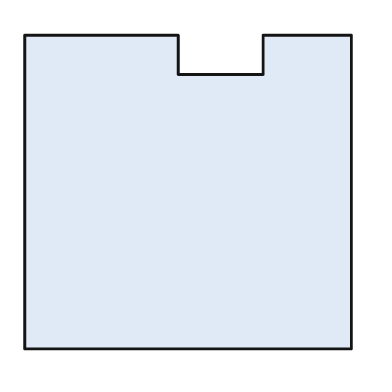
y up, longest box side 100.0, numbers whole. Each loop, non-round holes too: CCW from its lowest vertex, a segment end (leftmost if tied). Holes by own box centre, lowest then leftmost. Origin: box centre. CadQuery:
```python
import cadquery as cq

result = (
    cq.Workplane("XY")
    .moveTo(-50.0, -48.0)
    .lineTo(50.0, -48.0)
    .lineTo(50.0, 48.0)
    .lineTo(23.0, 48.0)
    .lineTo(23.0, 36.0)
    .lineTo(-3.0, 36.0)
    .lineTo(-3.0, 48.0)
    .lineTo(-50.0, 48.0)
    .close()
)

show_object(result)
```